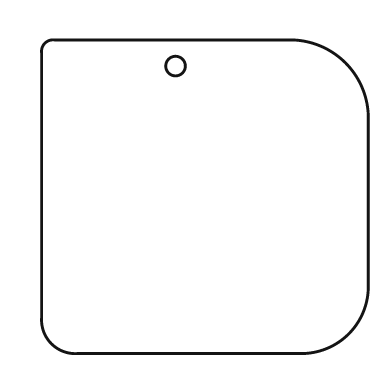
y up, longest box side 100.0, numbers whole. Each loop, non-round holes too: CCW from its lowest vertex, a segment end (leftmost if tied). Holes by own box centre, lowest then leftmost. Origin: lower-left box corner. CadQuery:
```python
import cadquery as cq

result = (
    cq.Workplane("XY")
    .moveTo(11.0, 0.0)
    .lineTo(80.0, 0.0)
    .threePointArc((94.0, 6.0), (100.0, 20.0))
    .lineTo(100.0, 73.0)
    .threePointArc((93.0, 89.0), (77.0, 96.0))
    .lineTo(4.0, 96.0)
    .threePointArc((1.0, 95.0), (0.0, 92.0))
    .lineTo(0.0, 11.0)
    .threePointArc((3.0, 3.0), (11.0, 0.0))
    .close()
    .moveTo(41.0, 88.0)
    .circle(3.0)
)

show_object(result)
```